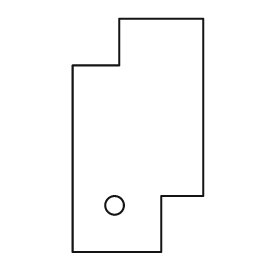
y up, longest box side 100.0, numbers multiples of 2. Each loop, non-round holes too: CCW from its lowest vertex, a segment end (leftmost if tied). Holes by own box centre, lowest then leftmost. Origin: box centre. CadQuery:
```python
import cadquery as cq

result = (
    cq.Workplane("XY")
    .moveTo(-28.0, -50.0)
    .lineTo(10.0, -50.0)
    .lineTo(10.0, -26.0)
    .lineTo(28.0, -26.0)
    .lineTo(28.0, 50.0)
    .lineTo(-8.0, 50.0)
    .lineTo(-8.0, 30.0)
    .lineTo(-28.0, 30.0)
    .close()
    .moveTo(-10.0, -30.0)
    .circle(4.0)
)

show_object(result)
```